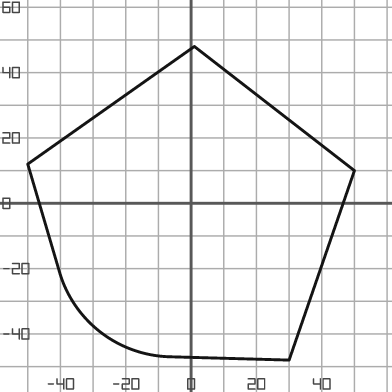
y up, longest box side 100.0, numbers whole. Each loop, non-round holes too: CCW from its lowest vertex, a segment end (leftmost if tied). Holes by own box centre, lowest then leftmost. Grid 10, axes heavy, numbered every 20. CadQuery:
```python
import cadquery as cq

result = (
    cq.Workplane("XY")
    .moveTo(30.0, -48.0)
    .lineTo(50.0, 10.0)
    .lineTo(1.0, 48.0)
    .lineTo(-50.0, 12.0)
    .lineTo(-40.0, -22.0)
    .threePointArc((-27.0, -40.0), (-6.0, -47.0))
    .close()
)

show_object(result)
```